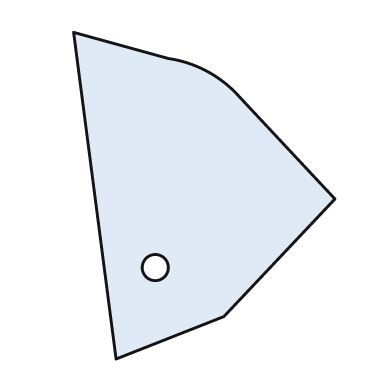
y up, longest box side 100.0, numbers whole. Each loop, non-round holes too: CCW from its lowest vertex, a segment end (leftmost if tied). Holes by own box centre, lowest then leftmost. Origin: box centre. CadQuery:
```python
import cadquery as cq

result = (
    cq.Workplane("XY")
    .moveTo(-27.0, -50.0)
    .lineTo(6.0, -37.0)
    .lineTo(40.0, -1.0)
    .lineTo(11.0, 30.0)
    .threePointArc((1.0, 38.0), (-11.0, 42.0))
    .lineTo(-40.0, 50.0)
    .close()
    .moveTo(-15.0, -22.0)
    .circle(4.0)
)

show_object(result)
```